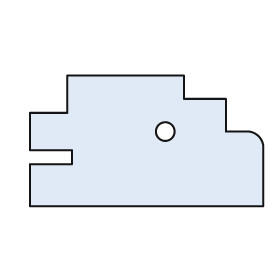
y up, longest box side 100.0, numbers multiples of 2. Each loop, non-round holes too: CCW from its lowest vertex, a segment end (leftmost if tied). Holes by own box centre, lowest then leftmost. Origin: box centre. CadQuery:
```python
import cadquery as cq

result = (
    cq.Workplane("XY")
    .moveTo(-50.0, -28.0)
    .lineTo(50.0, -28.0)
    .lineTo(50.0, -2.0)
    .threePointArc((48.0, 2.0), (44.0, 4.0))
    .lineTo(34.0, 4.0)
    .lineTo(34.0, 18.0)
    .lineTo(16.0, 18.0)
    .lineTo(16.0, 28.0)
    .lineTo(-34.0, 28.0)
    .lineTo(-34.0, 12.0)
    .lineTo(-50.0, 12.0)
    .lineTo(-50.0, -4.0)
    .lineTo(-32.0, -4.0)
    .lineTo(-32.0, -10.0)
    .lineTo(-50.0, -10.0)
    .close()
    .moveTo(8.0, 4.0)
    .circle(4.0)
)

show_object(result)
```